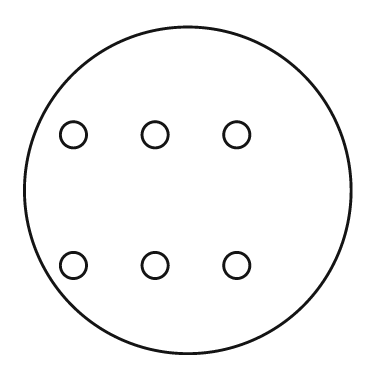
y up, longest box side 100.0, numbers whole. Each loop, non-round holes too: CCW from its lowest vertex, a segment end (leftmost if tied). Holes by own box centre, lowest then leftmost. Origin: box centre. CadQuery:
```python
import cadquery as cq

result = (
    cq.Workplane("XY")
    .moveTo(0.0, 0.0)
    .circle(50.0)
    .moveTo(-35.0, -23.0)
    .circle(4.0)
    .moveTo(-10.0, -23.0)
    .circle(4.0)
    .moveTo(15.0, -23.0)
    .circle(4.0)
    .moveTo(-35.0, 17.0)
    .circle(4.0)
    .moveTo(-10.0, 17.0)
    .circle(4.0)
    .moveTo(15.0, 17.0)
    .circle(4.0)
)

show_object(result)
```